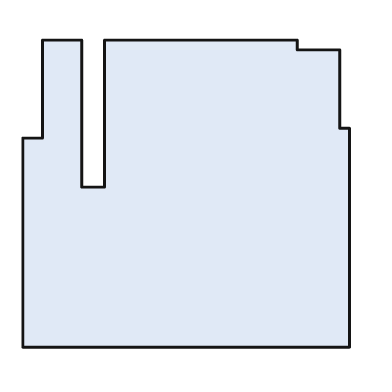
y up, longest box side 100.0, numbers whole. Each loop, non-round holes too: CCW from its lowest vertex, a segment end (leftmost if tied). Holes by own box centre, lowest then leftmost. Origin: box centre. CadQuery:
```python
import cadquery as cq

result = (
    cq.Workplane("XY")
    .moveTo(-50.0, -47.0)
    .lineTo(50.0, -47.0)
    .lineTo(50.0, 20.0)
    .lineTo(47.0, 20.0)
    .lineTo(47.0, 44.0)
    .lineTo(34.0, 44.0)
    .lineTo(34.0, 47.0)
    .lineTo(-25.0, 47.0)
    .lineTo(-25.0, 2.0)
    .lineTo(-32.0, 2.0)
    .lineTo(-32.0, 47.0)
    .lineTo(-44.0, 47.0)
    .lineTo(-44.0, 17.0)
    .lineTo(-50.0, 17.0)
    .close()
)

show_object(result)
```